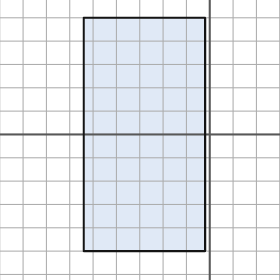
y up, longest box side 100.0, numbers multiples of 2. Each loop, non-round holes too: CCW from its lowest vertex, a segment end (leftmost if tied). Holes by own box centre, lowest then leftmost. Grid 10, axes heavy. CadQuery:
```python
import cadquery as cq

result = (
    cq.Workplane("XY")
    .moveTo(-54.0, -50.0)
    .lineTo(-2.0, -50.0)
    .lineTo(-2.0, 50.0)
    .lineTo(-54.0, 50.0)
    .close()
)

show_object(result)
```